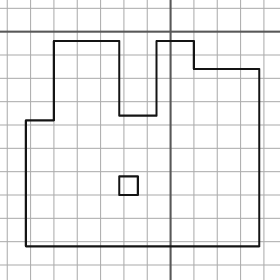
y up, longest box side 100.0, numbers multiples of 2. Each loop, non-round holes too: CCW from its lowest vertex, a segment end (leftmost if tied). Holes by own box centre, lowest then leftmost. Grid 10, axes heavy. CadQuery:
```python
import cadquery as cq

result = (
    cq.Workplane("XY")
    .moveTo(-62.0, -92.0)
    .lineTo(38.0, -92.0)
    .lineTo(38.0, -16.0)
    .lineTo(10.0, -16.0)
    .lineTo(10.0, -4.0)
    .lineTo(-6.0, -4.0)
    .lineTo(-6.0, -36.0)
    .lineTo(-22.0, -36.0)
    .lineTo(-22.0, -4.0)
    .lineTo(-50.0, -4.0)
    .lineTo(-50.0, -38.0)
    .lineTo(-62.0, -38.0)
    .close()
    .moveTo(-22.0, -70.0)
    .lineTo(-14.0, -70.0)
    .lineTo(-14.0, -62.0)
    .lineTo(-22.0, -62.0)
    .close()
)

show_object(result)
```